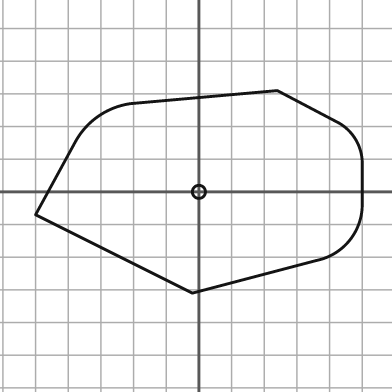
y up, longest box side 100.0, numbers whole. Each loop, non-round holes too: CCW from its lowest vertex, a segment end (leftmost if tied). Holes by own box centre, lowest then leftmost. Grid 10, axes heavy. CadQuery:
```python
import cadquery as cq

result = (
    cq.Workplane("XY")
    .moveTo(-2.0, -31.0)
    .lineTo(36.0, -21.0)
    .threePointArc((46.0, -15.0), (50.0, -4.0))
    .lineTo(50.0, 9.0)
    .threePointArc((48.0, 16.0), (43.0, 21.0))
    .lineTo(24.0, 31.0)
    .lineTo(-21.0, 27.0)
    .threePointArc((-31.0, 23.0), (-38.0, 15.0))
    .lineTo(-50.0, -7.0)
    .close()
    .moveTo(0.0, 0.0)
    .circle(2.0)
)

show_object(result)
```